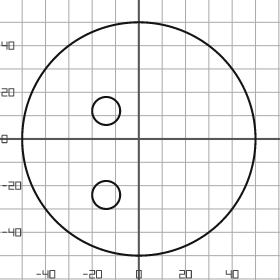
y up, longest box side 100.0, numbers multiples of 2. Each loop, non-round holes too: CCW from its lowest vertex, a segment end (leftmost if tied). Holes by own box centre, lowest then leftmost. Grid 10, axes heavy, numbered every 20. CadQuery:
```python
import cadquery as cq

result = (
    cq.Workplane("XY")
    .moveTo(0.0, 0.0)
    .circle(50.0)
    .moveTo(-14.0, -24.0)
    .circle(6.0)
    .moveTo(-14.0, 12.0)
    .circle(6.0)
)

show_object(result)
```